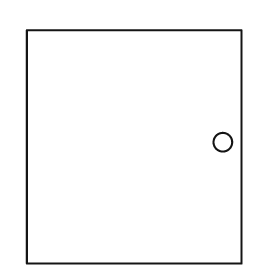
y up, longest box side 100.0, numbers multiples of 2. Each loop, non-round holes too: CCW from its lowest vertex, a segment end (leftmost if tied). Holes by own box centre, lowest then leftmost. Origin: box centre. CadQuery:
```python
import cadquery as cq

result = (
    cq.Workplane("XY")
    .moveTo(-46.0, -50.0)
    .lineTo(46.0, -50.0)
    .lineTo(46.0, 50.0)
    .lineTo(-46.0, 50.0)
    .close()
    .moveTo(38.0, 2.0)
    .circle(4.0)
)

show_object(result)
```